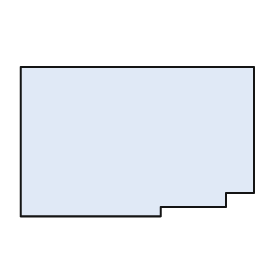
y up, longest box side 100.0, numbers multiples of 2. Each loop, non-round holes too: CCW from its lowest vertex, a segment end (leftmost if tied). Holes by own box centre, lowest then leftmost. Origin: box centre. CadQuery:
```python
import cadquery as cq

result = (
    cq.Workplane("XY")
    .moveTo(-50.0, -32.0)
    .lineTo(10.0, -32.0)
    .lineTo(10.0, -28.0)
    .lineTo(38.0, -28.0)
    .lineTo(38.0, -22.0)
    .lineTo(50.0, -22.0)
    .lineTo(50.0, 32.0)
    .lineTo(-50.0, 32.0)
    .close()
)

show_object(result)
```